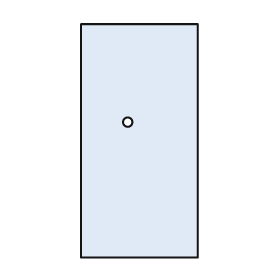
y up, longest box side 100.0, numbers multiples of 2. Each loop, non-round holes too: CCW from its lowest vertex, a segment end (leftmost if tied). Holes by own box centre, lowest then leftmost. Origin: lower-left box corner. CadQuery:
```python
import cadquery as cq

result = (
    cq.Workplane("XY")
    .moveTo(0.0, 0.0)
    .lineTo(50.0, 0.0)
    .lineTo(50.0, 100.0)
    .lineTo(0.0, 100.0)
    .close()
    .moveTo(20.0, 58.0)
    .circle(2.0)
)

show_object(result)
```